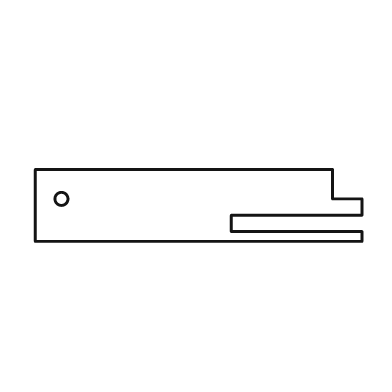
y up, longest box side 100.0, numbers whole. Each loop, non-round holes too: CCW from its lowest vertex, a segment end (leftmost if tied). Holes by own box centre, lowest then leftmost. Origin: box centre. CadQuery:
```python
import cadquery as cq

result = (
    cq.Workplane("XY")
    .moveTo(-50.0, -11.0)
    .lineTo(50.0, -11.0)
    .lineTo(50.0, -8.0)
    .lineTo(10.0, -8.0)
    .lineTo(10.0, -3.0)
    .lineTo(50.0, -3.0)
    .lineTo(50.0, 2.0)
    .lineTo(41.0, 2.0)
    .lineTo(41.0, 11.0)
    .lineTo(-50.0, 11.0)
    .close()
    .moveTo(-42.0, 2.0)
    .circle(2.0)
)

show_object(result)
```